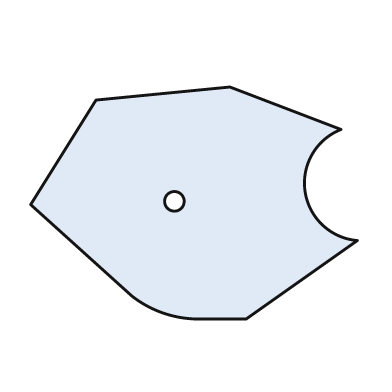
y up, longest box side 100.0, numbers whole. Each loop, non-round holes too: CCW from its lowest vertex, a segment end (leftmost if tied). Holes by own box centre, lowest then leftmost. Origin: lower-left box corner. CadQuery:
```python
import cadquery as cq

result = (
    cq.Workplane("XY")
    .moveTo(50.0, 0.0)
    .lineTo(66.0, 0.0)
    .lineTo(100.0, 24.0)
    .threePointArc((84.0, 39.0), (95.0, 58.0))
    .lineTo(61.0, 71.0)
    .lineTo(20.0, 67.0)
    .lineTo(0.0, 35.0)
    .lineTo(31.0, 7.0)
    .threePointArc((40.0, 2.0), (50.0, 0.0))
    .close()
    .moveTo(44.0, 36.0)
    .circle(3.0)
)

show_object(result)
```